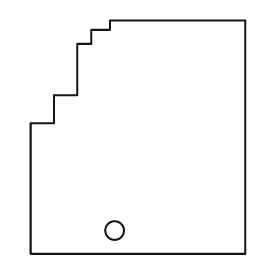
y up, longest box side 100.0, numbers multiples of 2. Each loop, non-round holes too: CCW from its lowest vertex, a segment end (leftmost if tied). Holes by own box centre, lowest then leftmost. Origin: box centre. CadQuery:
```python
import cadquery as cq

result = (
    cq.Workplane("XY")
    .moveTo(-46.0, -50.0)
    .lineTo(46.0, -50.0)
    .lineTo(46.0, 50.0)
    .lineTo(-12.0, 50.0)
    .lineTo(-12.0, 46.0)
    .lineTo(-20.0, 46.0)
    .lineTo(-20.0, 40.0)
    .lineTo(-26.0, 40.0)
    .lineTo(-26.0, 18.0)
    .lineTo(-36.0, 18.0)
    .lineTo(-36.0, 6.0)
    .lineTo(-46.0, 6.0)
    .close()
    .moveTo(-10.0, -40.0)
    .circle(4.0)
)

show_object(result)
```